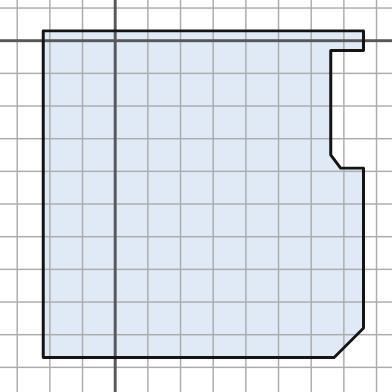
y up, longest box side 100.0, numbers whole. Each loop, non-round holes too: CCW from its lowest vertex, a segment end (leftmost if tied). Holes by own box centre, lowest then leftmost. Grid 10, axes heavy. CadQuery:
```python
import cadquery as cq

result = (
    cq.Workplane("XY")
    .moveTo(-22.0, -97.0)
    .lineTo(67.0, -97.0)
    .lineTo(76.0, -88.0)
    .lineTo(76.0, -39.0)
    .lineTo(69.0, -39.0)
    .lineTo(66.0, -35.0)
    .lineTo(66.0, -3.0)
    .lineTo(76.0, -3.0)
    .lineTo(76.0, 3.0)
    .lineTo(-22.0, 3.0)
    .close()
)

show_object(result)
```